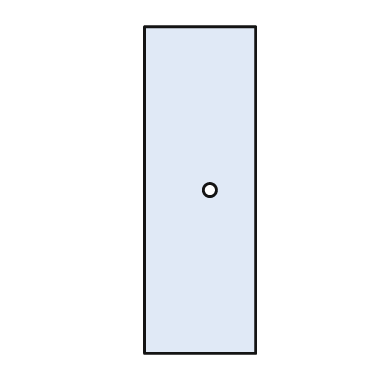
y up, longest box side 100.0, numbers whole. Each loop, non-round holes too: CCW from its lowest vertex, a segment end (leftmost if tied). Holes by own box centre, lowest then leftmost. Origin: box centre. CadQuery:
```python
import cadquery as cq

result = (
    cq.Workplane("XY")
    .moveTo(-17.0, -50.0)
    .lineTo(17.0, -50.0)
    .lineTo(17.0, 50.0)
    .lineTo(-17.0, 50.0)
    .close()
    .moveTo(3.0, 0.0)
    .circle(2.0)
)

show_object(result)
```